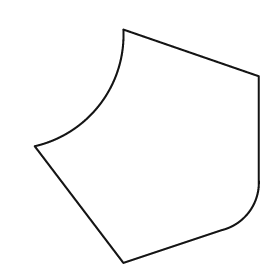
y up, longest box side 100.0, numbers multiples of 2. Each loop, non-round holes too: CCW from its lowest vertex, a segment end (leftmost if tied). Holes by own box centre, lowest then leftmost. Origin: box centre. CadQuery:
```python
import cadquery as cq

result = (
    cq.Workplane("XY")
    .moveTo(-10.0, -50.0)
    .lineTo(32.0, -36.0)
    .threePointArc((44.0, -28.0), (48.0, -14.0))
    .lineTo(48.0, 30.0)
    .lineTo(-10.0, 50.0)
    .threePointArc((-20.0, 18.0), (-48.0, 0.0))
    .close()
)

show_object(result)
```